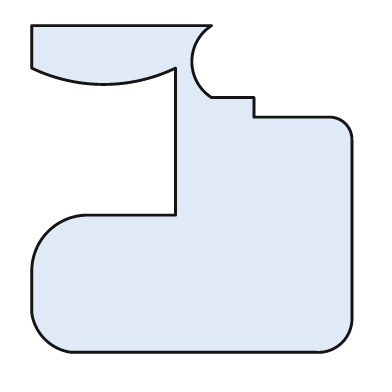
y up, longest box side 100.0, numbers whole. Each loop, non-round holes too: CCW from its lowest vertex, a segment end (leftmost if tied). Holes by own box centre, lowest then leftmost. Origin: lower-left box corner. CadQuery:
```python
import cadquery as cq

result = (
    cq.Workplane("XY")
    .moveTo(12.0, 0.0)
    .lineTo(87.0, 0.0)
    .threePointArc((95.0, 3.0), (98.0, 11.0))
    .lineTo(98.0, 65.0)
    .threePointArc((96.0, 70.0), (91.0, 72.0))
    .lineTo(68.0, 72.0)
    .lineTo(68.0, 78.0)
    .lineTo(55.0, 78.0)
    .threePointArc((49.0, 89.0), (55.0, 100.0))
    .lineTo(0.0, 100.0)
    .lineTo(0.0, 87.0)
    .threePointArc((22.0, 82.0), (44.0, 87.0))
    .lineTo(44.0, 42.0)
    .lineTo(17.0, 42.0)
    .threePointArc((5.0, 37.0), (0.0, 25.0))
    .lineTo(0.0, 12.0)
    .threePointArc((4.0, 4.0), (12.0, 0.0))
    .close()
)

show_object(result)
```